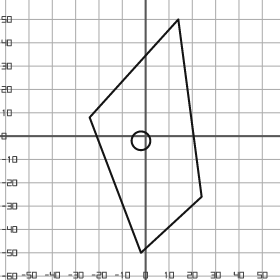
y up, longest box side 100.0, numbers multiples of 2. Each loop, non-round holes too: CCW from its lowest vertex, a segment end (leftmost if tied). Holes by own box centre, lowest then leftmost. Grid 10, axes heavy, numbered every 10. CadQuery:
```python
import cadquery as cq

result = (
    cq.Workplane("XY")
    .moveTo(-2.0, -50.0)
    .lineTo(24.0, -26.0)
    .lineTo(14.0, 50.0)
    .lineTo(-24.0, 8.0)
    .close()
    .moveTo(-2.0, -2.0)
    .circle(4.0)
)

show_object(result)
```